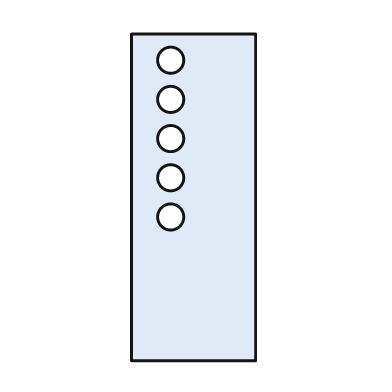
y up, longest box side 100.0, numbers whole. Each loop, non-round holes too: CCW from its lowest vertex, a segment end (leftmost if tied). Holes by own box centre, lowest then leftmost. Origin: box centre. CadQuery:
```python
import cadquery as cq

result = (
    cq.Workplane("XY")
    .moveTo(-19.0, -50.0)
    .lineTo(19.0, -50.0)
    .lineTo(19.0, 50.0)
    .lineTo(-19.0, 50.0)
    .close()
    .moveTo(-7.0, -6.0)
    .circle(4.0)
    .moveTo(-7.0, 6.0)
    .circle(4.0)
    .moveTo(-7.0, 18.0)
    .circle(4.0)
    .moveTo(-7.0, 30.0)
    .circle(4.0)
    .moveTo(-7.0, 42.0)
    .circle(4.0)
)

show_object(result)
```